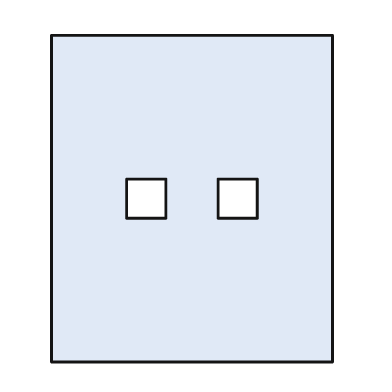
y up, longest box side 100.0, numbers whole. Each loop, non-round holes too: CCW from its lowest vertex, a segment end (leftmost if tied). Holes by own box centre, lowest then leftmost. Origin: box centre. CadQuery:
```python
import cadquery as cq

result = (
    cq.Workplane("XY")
    .moveTo(-43.0, -50.0)
    .lineTo(43.0, -50.0)
    .lineTo(43.0, 50.0)
    .lineTo(-43.0, 50.0)
    .close()
    .moveTo(-20.0, -6.0)
    .lineTo(-8.0, -6.0)
    .lineTo(-8.0, 6.0)
    .lineTo(-20.0, 6.0)
    .close()
    .moveTo(8.0, -6.0)
    .lineTo(20.0, -6.0)
    .lineTo(20.0, 6.0)
    .lineTo(8.0, 6.0)
    .close()
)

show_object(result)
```